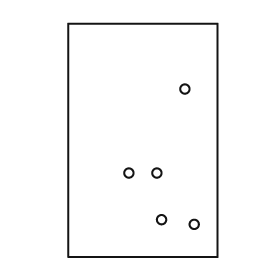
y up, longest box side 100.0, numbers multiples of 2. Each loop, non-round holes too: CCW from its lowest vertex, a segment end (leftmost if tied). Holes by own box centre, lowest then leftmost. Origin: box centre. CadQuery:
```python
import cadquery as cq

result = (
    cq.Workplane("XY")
    .moveTo(-32.0, -50.0)
    .lineTo(32.0, -50.0)
    .lineTo(32.0, 50.0)
    .lineTo(-32.0, 50.0)
    .close()
    .moveTo(22.0, -36.0)
    .circle(2.0)
    .moveTo(8.0, -34.0)
    .circle(2.0)
    .moveTo(-6.0, -14.0)
    .circle(2.0)
    .moveTo(6.0, -14.0)
    .circle(2.0)
    .moveTo(18.0, 22.0)
    .circle(2.0)
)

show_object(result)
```